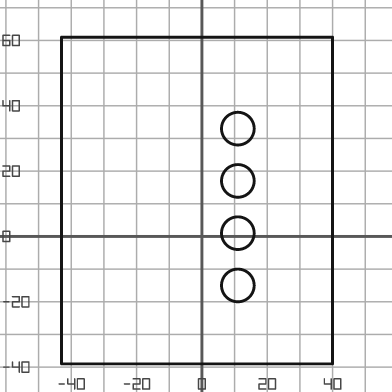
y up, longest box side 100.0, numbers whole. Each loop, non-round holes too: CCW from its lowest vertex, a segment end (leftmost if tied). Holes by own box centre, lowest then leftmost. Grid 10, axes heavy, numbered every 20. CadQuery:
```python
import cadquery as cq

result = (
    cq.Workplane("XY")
    .moveTo(-43.0, -39.0)
    .lineTo(40.0, -39.0)
    .lineTo(40.0, 61.0)
    .lineTo(-43.0, 61.0)
    .close()
    .moveTo(11.0, -15.0)
    .circle(5.0)
    .moveTo(11.0, 1.0)
    .circle(5.0)
    .moveTo(11.0, 17.0)
    .circle(5.0)
    .moveTo(11.0, 33.0)
    .circle(5.0)
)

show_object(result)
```